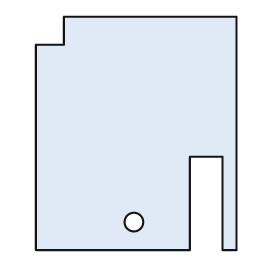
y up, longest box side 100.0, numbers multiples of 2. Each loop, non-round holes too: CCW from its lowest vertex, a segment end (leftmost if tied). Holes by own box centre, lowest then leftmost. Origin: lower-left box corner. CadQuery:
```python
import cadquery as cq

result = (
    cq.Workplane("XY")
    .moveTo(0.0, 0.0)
    .lineTo(66.0, 0.0)
    .lineTo(66.0, 40.0)
    .lineTo(80.0, 40.0)
    .lineTo(80.0, 0.0)
    .lineTo(86.0, 0.0)
    .lineTo(86.0, 100.0)
    .lineTo(12.0, 100.0)
    .lineTo(12.0, 88.0)
    .lineTo(0.0, 88.0)
    .close()
    .moveTo(42.0, 12.0)
    .circle(4.0)
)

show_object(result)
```